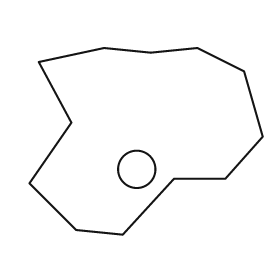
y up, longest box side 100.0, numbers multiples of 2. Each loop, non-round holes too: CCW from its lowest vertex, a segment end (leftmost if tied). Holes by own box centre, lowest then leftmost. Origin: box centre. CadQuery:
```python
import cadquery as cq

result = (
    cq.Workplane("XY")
    .moveTo(-10.0, -40.0)
    .lineTo(12.0, -16.0)
    .lineTo(34.0, -16.0)
    .lineTo(50.0, 2.0)
    .lineTo(42.0, 30.0)
    .lineTo(22.0, 40.0)
    .lineTo(2.0, 38.0)
    .lineTo(-18.0, 40.0)
    .lineTo(-46.0, 34.0)
    .lineTo(-32.0, 8.0)
    .lineTo(-50.0, -18.0)
    .lineTo(-30.0, -38.0)
    .close()
    .moveTo(-4.0, -12.0)
    .circle(8.0)
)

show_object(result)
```